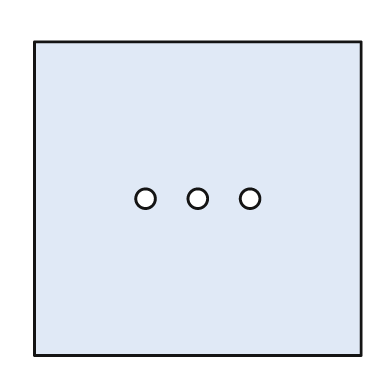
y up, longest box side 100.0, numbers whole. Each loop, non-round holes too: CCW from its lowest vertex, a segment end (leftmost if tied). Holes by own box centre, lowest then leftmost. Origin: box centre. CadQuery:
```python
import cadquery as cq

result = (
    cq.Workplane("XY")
    .moveTo(-50.0, -48.0)
    .lineTo(50.0, -48.0)
    .lineTo(50.0, 48.0)
    .lineTo(-50.0, 48.0)
    .close()
    .moveTo(-16.0, 0.0)
    .circle(3.0)
    .moveTo(0.0, 0.0)
    .circle(3.0)
    .moveTo(16.0, 0.0)
    .circle(3.0)
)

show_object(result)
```